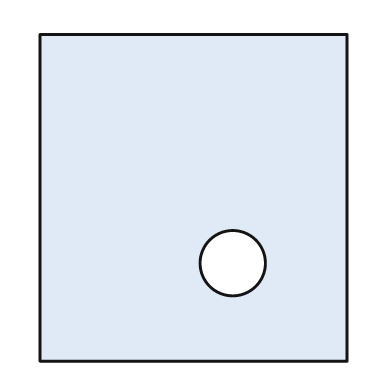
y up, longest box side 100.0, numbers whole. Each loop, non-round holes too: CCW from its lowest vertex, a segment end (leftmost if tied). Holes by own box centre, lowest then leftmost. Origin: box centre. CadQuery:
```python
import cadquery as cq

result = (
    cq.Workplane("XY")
    .moveTo(-47.0, -50.0)
    .lineTo(47.0, -50.0)
    .lineTo(47.0, 50.0)
    .lineTo(-47.0, 50.0)
    .close()
    .moveTo(12.0, -20.0)
    .circle(10.0)
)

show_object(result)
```